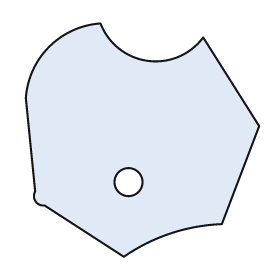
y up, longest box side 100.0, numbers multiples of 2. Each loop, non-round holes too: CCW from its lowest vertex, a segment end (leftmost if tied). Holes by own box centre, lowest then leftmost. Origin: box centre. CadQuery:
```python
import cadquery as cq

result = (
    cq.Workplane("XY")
    .moveTo(-8.0, -50.0)
    .threePointArc((12.0, -40.0), (34.0, -36.0))
    .lineTo(50.0, 6.0)
    .lineTo(26.0, 44.0)
    .threePointArc((2.0, 34.0), (-18.0, 50.0))
    .threePointArc((-40.0, 40.0), (-50.0, 18.0))
    .lineTo(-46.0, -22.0)
    .threePointArc((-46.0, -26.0), (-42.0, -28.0))
    .close()
    .moveTo(-6.0, -18.0)
    .circle(6.0)
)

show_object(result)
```